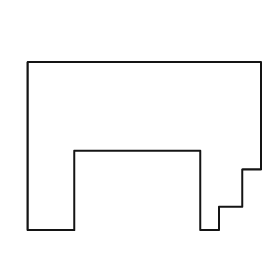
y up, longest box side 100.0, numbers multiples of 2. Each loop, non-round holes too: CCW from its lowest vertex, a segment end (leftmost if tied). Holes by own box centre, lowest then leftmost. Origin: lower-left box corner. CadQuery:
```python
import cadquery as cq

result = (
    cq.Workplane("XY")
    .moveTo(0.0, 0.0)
    .lineTo(20.0, 0.0)
    .lineTo(20.0, 34.0)
    .lineTo(74.0, 34.0)
    .lineTo(74.0, 0.0)
    .lineTo(82.0, 0.0)
    .lineTo(82.0, 10.0)
    .lineTo(92.0, 10.0)
    .lineTo(92.0, 26.0)
    .lineTo(100.0, 26.0)
    .lineTo(100.0, 72.0)
    .lineTo(0.0, 72.0)
    .close()
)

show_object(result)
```